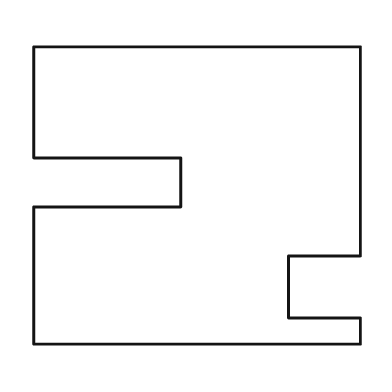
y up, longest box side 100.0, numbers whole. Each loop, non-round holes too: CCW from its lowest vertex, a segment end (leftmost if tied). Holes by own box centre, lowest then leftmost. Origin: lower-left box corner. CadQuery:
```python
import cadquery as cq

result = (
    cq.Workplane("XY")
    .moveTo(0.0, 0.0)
    .lineTo(100.0, 0.0)
    .lineTo(100.0, 8.0)
    .lineTo(78.0, 8.0)
    .lineTo(78.0, 27.0)
    .lineTo(100.0, 27.0)
    .lineTo(100.0, 91.0)
    .lineTo(0.0, 91.0)
    .lineTo(0.0, 57.0)
    .lineTo(45.0, 57.0)
    .lineTo(45.0, 42.0)
    .lineTo(0.0, 42.0)
    .close()
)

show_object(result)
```